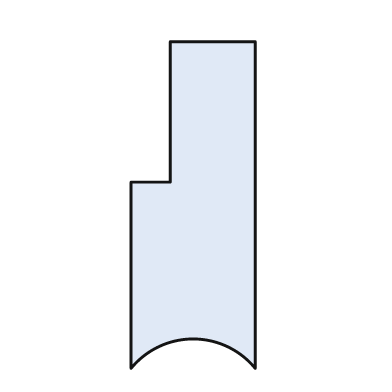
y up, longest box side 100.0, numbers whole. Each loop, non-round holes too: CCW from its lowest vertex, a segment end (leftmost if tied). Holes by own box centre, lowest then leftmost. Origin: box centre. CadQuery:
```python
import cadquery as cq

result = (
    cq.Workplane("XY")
    .moveTo(-19.0, -50.0)
    .threePointArc((0.0, -41.0), (19.0, -50.0))
    .lineTo(19.0, 50.0)
    .lineTo(-7.0, 50.0)
    .lineTo(-7.0, 7.0)
    .lineTo(-19.0, 7.0)
    .close()
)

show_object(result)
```